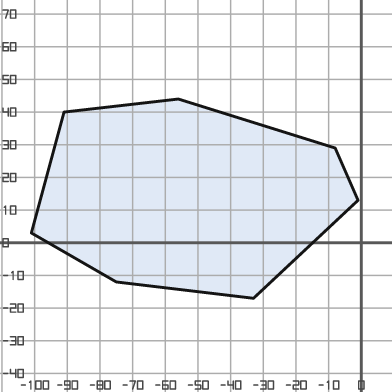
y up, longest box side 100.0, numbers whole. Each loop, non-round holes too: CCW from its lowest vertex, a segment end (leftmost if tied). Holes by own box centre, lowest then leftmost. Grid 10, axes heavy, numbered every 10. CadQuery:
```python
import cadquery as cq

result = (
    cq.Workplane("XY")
    .moveTo(-33.0, -17.0)
    .lineTo(-1.0, 13.0)
    .lineTo(-8.0, 29.0)
    .lineTo(-56.0, 44.0)
    .lineTo(-91.0, 40.0)
    .lineTo(-101.0, 3.0)
    .lineTo(-75.0, -12.0)
    .close()
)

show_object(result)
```